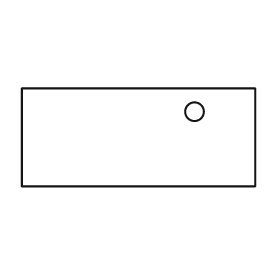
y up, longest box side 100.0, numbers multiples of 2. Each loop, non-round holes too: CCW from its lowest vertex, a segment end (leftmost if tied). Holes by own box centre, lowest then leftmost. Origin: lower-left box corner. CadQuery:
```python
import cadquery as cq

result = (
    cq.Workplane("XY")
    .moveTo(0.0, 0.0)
    .lineTo(100.0, 0.0)
    .lineTo(100.0, 42.0)
    .lineTo(0.0, 42.0)
    .close()
    .moveTo(74.0, 32.0)
    .circle(4.0)
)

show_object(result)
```